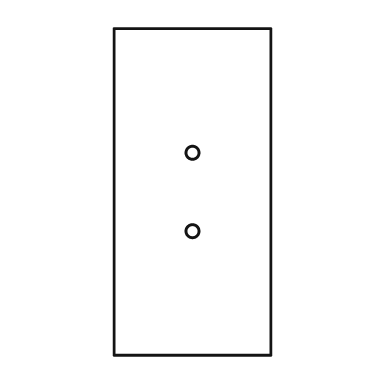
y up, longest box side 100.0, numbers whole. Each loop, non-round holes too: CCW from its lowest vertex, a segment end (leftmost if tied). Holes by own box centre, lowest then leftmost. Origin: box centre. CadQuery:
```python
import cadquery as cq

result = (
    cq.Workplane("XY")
    .moveTo(-24.0, -50.0)
    .lineTo(24.0, -50.0)
    .lineTo(24.0, 50.0)
    .lineTo(-24.0, 50.0)
    .close()
    .moveTo(0.0, -12.0)
    .circle(2.0)
    .moveTo(0.0, 12.0)
    .circle(2.0)
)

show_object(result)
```